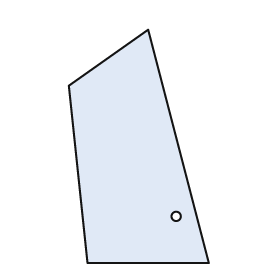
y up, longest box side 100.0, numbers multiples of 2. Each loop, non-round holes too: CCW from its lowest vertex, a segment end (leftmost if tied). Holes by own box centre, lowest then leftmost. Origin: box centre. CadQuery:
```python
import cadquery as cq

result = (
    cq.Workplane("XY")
    .moveTo(-22.0, -50.0)
    .lineTo(30.0, -50.0)
    .lineTo(4.0, 50.0)
    .lineTo(-30.0, 26.0)
    .close()
    .moveTo(16.0, -30.0)
    .circle(2.0)
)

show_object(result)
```